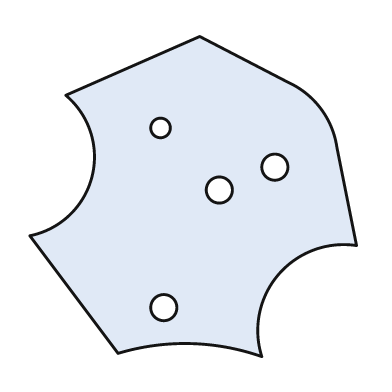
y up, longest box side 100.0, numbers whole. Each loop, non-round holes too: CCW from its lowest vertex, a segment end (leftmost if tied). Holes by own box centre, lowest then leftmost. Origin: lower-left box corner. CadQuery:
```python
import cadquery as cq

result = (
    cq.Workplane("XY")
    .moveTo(71.0, 0.0)
    .threePointArc((76.0, 25.0), (100.0, 34.0))
    .lineTo(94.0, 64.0)
    .threePointArc((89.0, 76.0), (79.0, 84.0))
    .lineTo(52.0, 98.0)
    .lineTo(11.0, 80.0)
    .threePointArc((19.0, 55.0), (0.0, 37.0))
    .lineTo(27.0, 1.0)
    .threePointArc((49.0, 4.0), (71.0, 0.0))
    .close()
    .moveTo(41.0, 15.0)
    .circle(4.0)
    .moveTo(58.0, 51.0)
    .circle(4.0)
    .moveTo(75.0, 58.0)
    .circle(4.0)
    .moveTo(40.0, 70.0)
    .circle(3.0)
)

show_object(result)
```